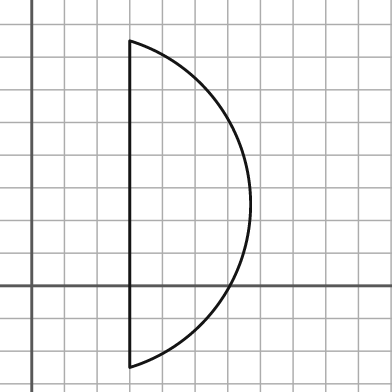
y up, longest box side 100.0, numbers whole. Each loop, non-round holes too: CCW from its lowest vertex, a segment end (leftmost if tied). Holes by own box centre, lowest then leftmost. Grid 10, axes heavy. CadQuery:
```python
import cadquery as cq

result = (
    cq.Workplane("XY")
    .moveTo(30.0, -25.0)
    .threePointArc((67.0, 25.0), (30.0, 75.0))
    .close()
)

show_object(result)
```